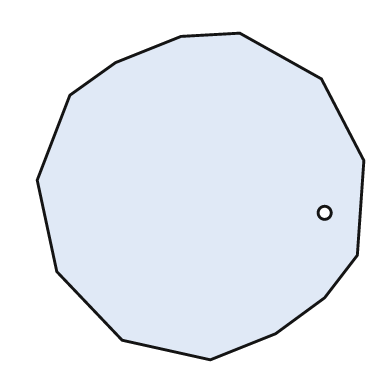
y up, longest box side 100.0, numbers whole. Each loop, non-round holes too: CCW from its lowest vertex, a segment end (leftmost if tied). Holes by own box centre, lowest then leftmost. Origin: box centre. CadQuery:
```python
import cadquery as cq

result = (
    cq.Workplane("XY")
    .moveTo(3.0, -50.0)
    .lineTo(23.0, -42.0)
    .lineTo(38.0, -31.0)
    .lineTo(48.0, -18.0)
    .lineTo(50.0, 11.0)
    .lineTo(37.0, 36.0)
    .lineTo(12.0, 50.0)
    .lineTo(-6.0, 49.0)
    .lineTo(-26.0, 41.0)
    .lineTo(-40.0, 31.0)
    .lineTo(-50.0, 5.0)
    .lineTo(-44.0, -23.0)
    .lineTo(-24.0, -44.0)
    .close()
    .moveTo(38.0, -5.0)
    .circle(2.0)
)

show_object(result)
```